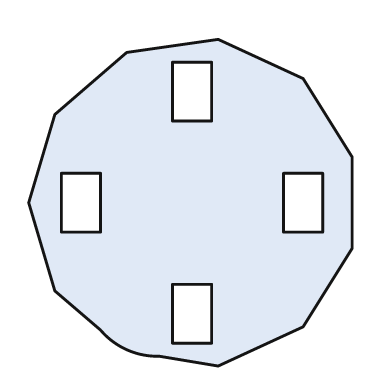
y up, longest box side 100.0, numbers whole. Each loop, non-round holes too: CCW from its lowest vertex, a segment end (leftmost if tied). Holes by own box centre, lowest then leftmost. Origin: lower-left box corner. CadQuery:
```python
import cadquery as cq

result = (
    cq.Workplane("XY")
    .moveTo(58.0, 0.0)
    .lineTo(84.0, 12.0)
    .lineTo(99.0, 36.0)
    .lineTo(99.0, 64.0)
    .lineTo(84.0, 88.0)
    .lineTo(58.0, 100.0)
    .lineTo(30.0, 96.0)
    .lineTo(8.0, 77.0)
    .lineTo(0.0, 50.0)
    .lineTo(8.0, 23.0)
    .lineTo(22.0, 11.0)
    .threePointArc((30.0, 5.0), (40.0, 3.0))
    .close()
    .moveTo(44.0, 7.0)
    .lineTo(56.0, 7.0)
    .lineTo(56.0, 25.0)
    .lineTo(44.0, 25.0)
    .close()
    .moveTo(10.0, 41.0)
    .lineTo(22.0, 41.0)
    .lineTo(22.0, 59.0)
    .lineTo(10.0, 59.0)
    .close()
    .moveTo(78.0, 41.0)
    .lineTo(90.0, 41.0)
    .lineTo(90.0, 59.0)
    .lineTo(78.0, 59.0)
    .close()
    .moveTo(44.0, 75.0)
    .lineTo(56.0, 75.0)
    .lineTo(56.0, 93.0)
    .lineTo(44.0, 93.0)
    .close()
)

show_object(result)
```